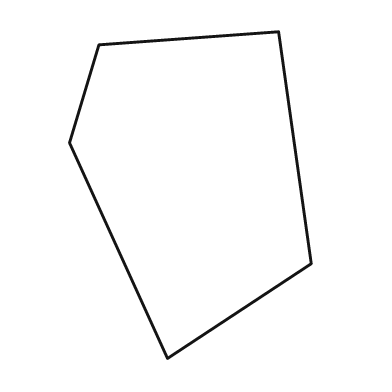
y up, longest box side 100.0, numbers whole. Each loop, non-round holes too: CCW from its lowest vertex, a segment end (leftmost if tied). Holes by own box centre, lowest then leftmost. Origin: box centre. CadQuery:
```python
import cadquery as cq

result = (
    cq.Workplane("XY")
    .moveTo(-7.0, -50.0)
    .lineTo(37.0, -21.0)
    .lineTo(27.0, 50.0)
    .lineTo(-28.0, 46.0)
    .lineTo(-37.0, 16.0)
    .close()
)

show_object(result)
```